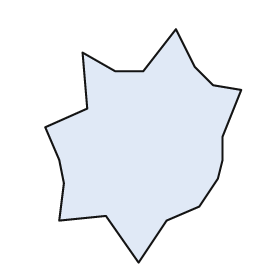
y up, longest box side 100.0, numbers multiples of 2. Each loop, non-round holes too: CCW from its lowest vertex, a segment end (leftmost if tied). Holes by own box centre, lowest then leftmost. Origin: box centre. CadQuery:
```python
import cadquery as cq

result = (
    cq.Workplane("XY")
    .moveTo(-2.0, -50.0)
    .lineTo(10.0, -32.0)
    .lineTo(24.0, -26.0)
    .lineTo(32.0, -14.0)
    .lineTo(34.0, -6.0)
    .lineTo(34.0, 4.0)
    .lineTo(42.0, 24.0)
    .lineTo(30.0, 26.0)
    .lineTo(22.0, 34.0)
    .lineTo(14.0, 50.0)
    .lineTo(0.0, 32.0)
    .lineTo(-12.0, 32.0)
    .lineTo(-26.0, 40.0)
    .lineTo(-24.0, 16.0)
    .lineTo(-42.0, 8.0)
    .lineTo(-36.0, -6.0)
    .lineTo(-34.0, -16.0)
    .lineTo(-36.0, -32.0)
    .lineTo(-16.0, -30.0)
    .close()
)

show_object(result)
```